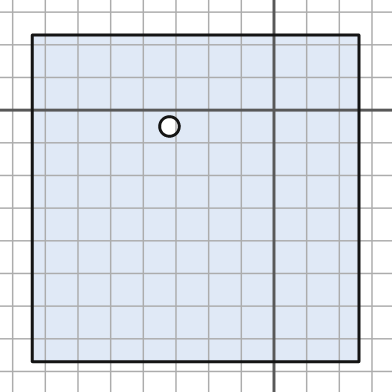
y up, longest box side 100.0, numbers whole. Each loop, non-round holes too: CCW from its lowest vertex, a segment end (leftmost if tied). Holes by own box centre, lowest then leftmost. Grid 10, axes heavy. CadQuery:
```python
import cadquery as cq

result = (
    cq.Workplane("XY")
    .moveTo(-74.0, -77.0)
    .lineTo(26.0, -77.0)
    .lineTo(26.0, 23.0)
    .lineTo(-74.0, 23.0)
    .close()
    .moveTo(-32.0, -5.0)
    .circle(3.0)
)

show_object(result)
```